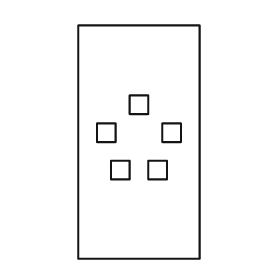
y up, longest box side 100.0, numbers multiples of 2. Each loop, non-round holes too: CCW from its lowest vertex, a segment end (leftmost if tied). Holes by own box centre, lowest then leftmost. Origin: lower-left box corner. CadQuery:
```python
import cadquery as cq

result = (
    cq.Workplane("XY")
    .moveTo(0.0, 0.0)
    .lineTo(52.0, 0.0)
    .lineTo(52.0, 100.0)
    .lineTo(0.0, 100.0)
    .close()
    .moveTo(14.0, 34.0)
    .lineTo(22.0, 34.0)
    .lineTo(22.0, 42.0)
    .lineTo(14.0, 42.0)
    .close()
    .moveTo(30.0, 34.0)
    .lineTo(38.0, 34.0)
    .lineTo(38.0, 42.0)
    .lineTo(30.0, 42.0)
    .close()
    .moveTo(8.0, 50.0)
    .lineTo(16.0, 50.0)
    .lineTo(16.0, 58.0)
    .lineTo(8.0, 58.0)
    .close()
    .moveTo(36.0, 50.0)
    .lineTo(44.0, 50.0)
    .lineTo(44.0, 58.0)
    .lineTo(36.0, 58.0)
    .close()
    .moveTo(22.0, 62.0)
    .lineTo(30.0, 62.0)
    .lineTo(30.0, 70.0)
    .lineTo(22.0, 70.0)
    .close()
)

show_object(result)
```